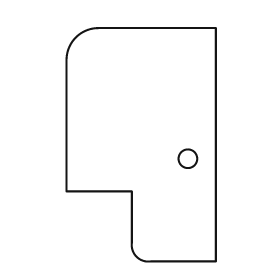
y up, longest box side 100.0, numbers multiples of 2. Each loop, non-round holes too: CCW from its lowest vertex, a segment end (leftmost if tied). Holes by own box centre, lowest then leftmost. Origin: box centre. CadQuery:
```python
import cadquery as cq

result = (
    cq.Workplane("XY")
    .moveTo(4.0, -50.0)
    .lineTo(32.0, -50.0)
    .lineTo(32.0, 50.0)
    .lineTo(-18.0, 50.0)
    .threePointArc((-28.0, 46.0), (-32.0, 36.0))
    .lineTo(-32.0, -20.0)
    .lineTo(-4.0, -20.0)
    .lineTo(-4.0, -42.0)
    .threePointArc((-2.0, -48.0), (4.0, -50.0))
    .close()
    .moveTo(20.0, -6.0)
    .circle(4.0)
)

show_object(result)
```